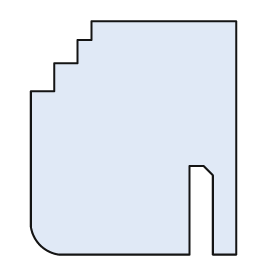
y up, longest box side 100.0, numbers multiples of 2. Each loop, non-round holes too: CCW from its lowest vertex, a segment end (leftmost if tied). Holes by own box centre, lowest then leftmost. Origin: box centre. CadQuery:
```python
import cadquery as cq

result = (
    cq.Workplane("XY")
    .moveTo(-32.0, -50.0)
    .lineTo(24.0, -50.0)
    .lineTo(24.0, -12.0)
    .lineTo(30.0, -12.0)
    .lineTo(34.0, -16.0)
    .lineTo(34.0, -50.0)
    .lineTo(44.0, -50.0)
    .lineTo(44.0, 50.0)
    .lineTo(-18.0, 50.0)
    .lineTo(-18.0, 42.0)
    .lineTo(-24.0, 42.0)
    .lineTo(-24.0, 32.0)
    .lineTo(-34.0, 32.0)
    .lineTo(-34.0, 20.0)
    .lineTo(-44.0, 20.0)
    .lineTo(-44.0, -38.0)
    .threePointArc((-40.0, -46.0), (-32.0, -50.0))
    .close()
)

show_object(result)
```